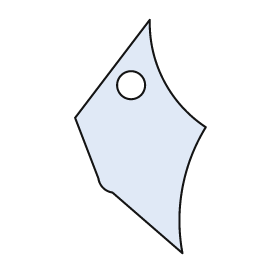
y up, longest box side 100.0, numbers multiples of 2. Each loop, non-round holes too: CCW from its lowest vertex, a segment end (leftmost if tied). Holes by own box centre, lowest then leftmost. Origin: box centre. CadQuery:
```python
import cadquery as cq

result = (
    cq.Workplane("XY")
    .moveTo(18.0, -50.0)
    .threePointArc((18.0, -22.0), (28.0, 4.0))
    .threePointArc((10.0, 24.0), (4.0, 50.0))
    .lineTo(-28.0, 8.0)
    .lineTo(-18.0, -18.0)
    .threePointArc((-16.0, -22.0), (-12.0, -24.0))
    .close()
    .moveTo(-4.0, 22.0)
    .circle(6.0)
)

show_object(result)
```